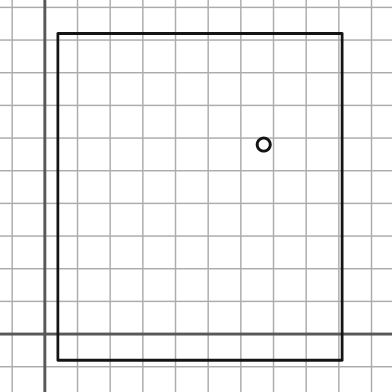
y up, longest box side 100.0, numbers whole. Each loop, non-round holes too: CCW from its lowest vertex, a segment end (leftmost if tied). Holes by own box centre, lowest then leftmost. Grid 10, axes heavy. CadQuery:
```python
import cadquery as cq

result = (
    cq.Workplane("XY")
    .moveTo(4.0, -8.0)
    .lineTo(91.0, -8.0)
    .lineTo(91.0, 92.0)
    .lineTo(4.0, 92.0)
    .close()
    .moveTo(67.0, 58.0)
    .circle(2.0)
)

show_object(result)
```